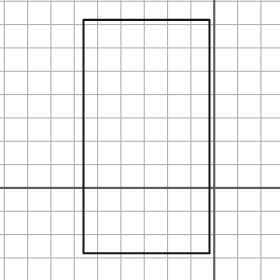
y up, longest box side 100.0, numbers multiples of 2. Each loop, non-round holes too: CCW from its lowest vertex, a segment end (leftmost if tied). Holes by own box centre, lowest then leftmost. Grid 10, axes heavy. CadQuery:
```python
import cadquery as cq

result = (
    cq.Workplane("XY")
    .moveTo(-56.0, -28.0)
    .lineTo(-2.0, -28.0)
    .lineTo(-2.0, 72.0)
    .lineTo(-56.0, 72.0)
    .close()
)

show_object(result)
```